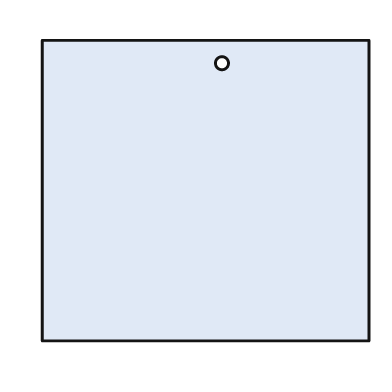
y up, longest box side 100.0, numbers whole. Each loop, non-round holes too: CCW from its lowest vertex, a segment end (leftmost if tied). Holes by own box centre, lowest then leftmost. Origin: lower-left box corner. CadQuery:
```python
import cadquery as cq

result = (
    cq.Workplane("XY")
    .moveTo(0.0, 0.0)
    .lineTo(100.0, 0.0)
    .lineTo(100.0, 92.0)
    .lineTo(0.0, 92.0)
    .close()
    .moveTo(55.0, 85.0)
    .circle(2.0)
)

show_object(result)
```